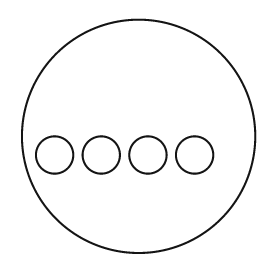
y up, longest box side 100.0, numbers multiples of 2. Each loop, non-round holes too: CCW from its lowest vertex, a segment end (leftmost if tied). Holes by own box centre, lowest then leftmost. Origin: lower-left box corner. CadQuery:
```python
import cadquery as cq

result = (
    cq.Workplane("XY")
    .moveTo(50.0, 50.0)
    .circle(50.0)
    .moveTo(14.0, 42.0)
    .circle(8.0)
    .moveTo(34.0, 42.0)
    .circle(8.0)
    .moveTo(54.0, 42.0)
    .circle(8.0)
    .moveTo(74.0, 42.0)
    .circle(8.0)
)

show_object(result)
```